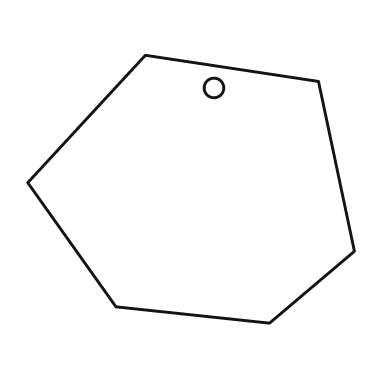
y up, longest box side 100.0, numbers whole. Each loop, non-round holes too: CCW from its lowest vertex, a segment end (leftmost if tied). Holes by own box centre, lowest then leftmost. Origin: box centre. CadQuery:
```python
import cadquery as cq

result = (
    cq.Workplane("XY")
    .moveTo(24.0, -41.0)
    .lineTo(50.0, -19.0)
    .lineTo(39.0, 33.0)
    .lineTo(-14.0, 41.0)
    .lineTo(-50.0, 2.0)
    .lineTo(-23.0, -36.0)
    .close()
    .moveTo(7.0, 31.0)
    .circle(3.0)
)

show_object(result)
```